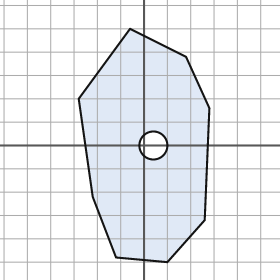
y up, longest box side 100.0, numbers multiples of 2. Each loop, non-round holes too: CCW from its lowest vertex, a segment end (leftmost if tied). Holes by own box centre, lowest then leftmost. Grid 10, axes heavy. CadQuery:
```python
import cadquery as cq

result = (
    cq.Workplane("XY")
    .moveTo(10.0, -50.0)
    .lineTo(26.0, -32.0)
    .lineTo(28.0, 16.0)
    .lineTo(18.0, 38.0)
    .lineTo(-6.0, 50.0)
    .lineTo(-28.0, 20.0)
    .lineTo(-22.0, -22.0)
    .lineTo(-12.0, -48.0)
    .close()
    .moveTo(4.0, 0.0)
    .circle(6.0)
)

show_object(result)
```